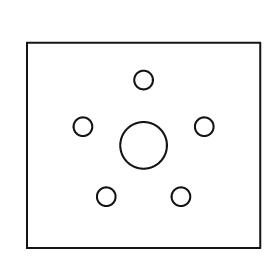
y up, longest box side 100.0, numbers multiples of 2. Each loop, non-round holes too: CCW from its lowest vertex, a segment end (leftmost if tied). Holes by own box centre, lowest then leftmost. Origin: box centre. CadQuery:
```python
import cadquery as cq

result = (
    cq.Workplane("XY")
    .moveTo(-50.0, -44.0)
    .lineTo(50.0, -44.0)
    .lineTo(50.0, 44.0)
    .lineTo(-50.0, 44.0)
    .close()
    .moveTo(-16.0, -22.0)
    .circle(4.0)
    .moveTo(16.0, -22.0)
    .circle(4.0)
    .moveTo(0.0, 0.0)
    .circle(10.0)
    .moveTo(-26.0, 8.0)
    .circle(4.0)
    .moveTo(26.0, 8.0)
    .circle(4.0)
    .moveTo(0.0, 28.0)
    .circle(4.0)
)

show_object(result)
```